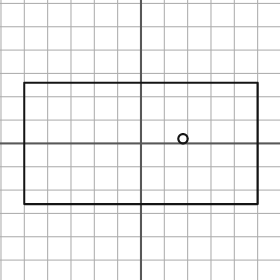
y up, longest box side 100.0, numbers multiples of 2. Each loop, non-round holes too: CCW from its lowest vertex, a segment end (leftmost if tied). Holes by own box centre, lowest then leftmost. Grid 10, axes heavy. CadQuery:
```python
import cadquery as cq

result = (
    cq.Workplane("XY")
    .moveTo(-50.0, -26.0)
    .lineTo(50.0, -26.0)
    .lineTo(50.0, 26.0)
    .lineTo(-50.0, 26.0)
    .close()
    .moveTo(18.0, 2.0)
    .circle(2.0)
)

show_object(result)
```